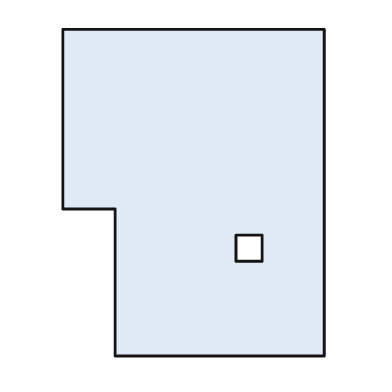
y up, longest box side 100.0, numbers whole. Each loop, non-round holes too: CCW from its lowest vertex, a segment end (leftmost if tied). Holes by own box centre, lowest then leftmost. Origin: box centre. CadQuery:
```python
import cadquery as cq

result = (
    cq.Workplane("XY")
    .moveTo(-24.0, -50.0)
    .lineTo(40.0, -50.0)
    .lineTo(40.0, 50.0)
    .lineTo(-40.0, 50.0)
    .lineTo(-40.0, -5.0)
    .lineTo(-24.0, -5.0)
    .close()
    .moveTo(13.0, -21.0)
    .lineTo(21.0, -21.0)
    .lineTo(21.0, -13.0)
    .lineTo(13.0, -13.0)
    .close()
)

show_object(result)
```